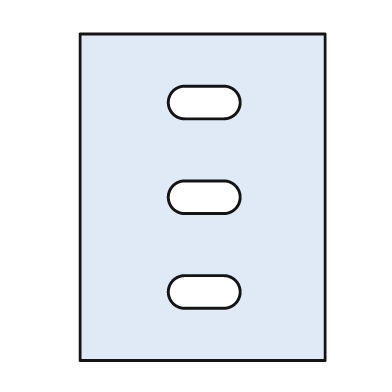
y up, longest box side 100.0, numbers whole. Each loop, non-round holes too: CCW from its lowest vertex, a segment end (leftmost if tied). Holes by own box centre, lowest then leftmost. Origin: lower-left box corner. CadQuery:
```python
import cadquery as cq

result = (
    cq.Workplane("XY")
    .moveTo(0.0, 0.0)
    .lineTo(75.0, 0.0)
    .lineTo(75.0, 100.0)
    .lineTo(0.0, 100.0)
    .close()
    .moveTo(32.0, 16.0)
    .lineTo(44.0, 16.0)
    .threePointArc((49.0, 21.0), (44.0, 26.0))
    .lineTo(32.0, 26.0)
    .threePointArc((27.0, 21.0), (32.0, 16.0))
    .close()
    .moveTo(32.0, 45.0)
    .lineTo(44.0, 45.0)
    .threePointArc((49.0, 50.0), (44.0, 55.0))
    .lineTo(32.0, 55.0)
    .threePointArc((27.0, 50.0), (32.0, 45.0))
    .close()
    .moveTo(32.0, 74.0)
    .lineTo(44.0, 74.0)
    .threePointArc((49.0, 79.0), (44.0, 84.0))
    .lineTo(32.0, 84.0)
    .threePointArc((27.0, 79.0), (32.0, 74.0))
    .close()
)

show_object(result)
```